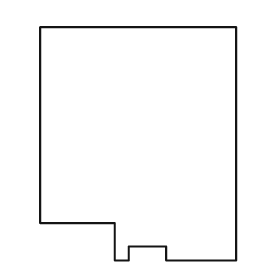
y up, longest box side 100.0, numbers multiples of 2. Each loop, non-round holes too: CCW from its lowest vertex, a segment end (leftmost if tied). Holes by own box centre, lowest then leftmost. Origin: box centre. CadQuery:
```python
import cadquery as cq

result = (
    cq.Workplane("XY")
    .moveTo(-10.0, -50.0)
    .lineTo(-4.0, -50.0)
    .lineTo(-4.0, -44.0)
    .lineTo(12.0, -44.0)
    .lineTo(12.0, -50.0)
    .lineTo(42.0, -50.0)
    .lineTo(42.0, 50.0)
    .lineTo(-42.0, 50.0)
    .lineTo(-42.0, -34.0)
    .lineTo(-10.0, -34.0)
    .close()
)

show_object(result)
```